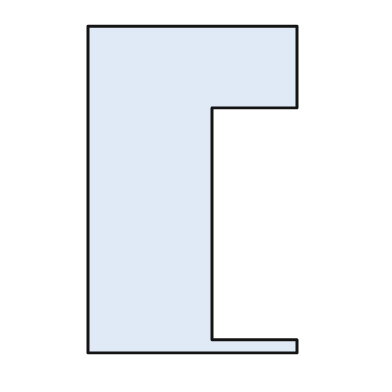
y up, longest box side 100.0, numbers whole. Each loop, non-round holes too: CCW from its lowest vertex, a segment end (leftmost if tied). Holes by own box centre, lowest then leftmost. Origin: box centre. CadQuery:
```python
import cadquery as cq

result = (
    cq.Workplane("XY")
    .moveTo(-32.0, -50.0)
    .lineTo(32.0, -50.0)
    .lineTo(32.0, -46.0)
    .lineTo(6.0, -46.0)
    .lineTo(6.0, 25.0)
    .lineTo(32.0, 25.0)
    .lineTo(32.0, 50.0)
    .lineTo(-32.0, 50.0)
    .close()
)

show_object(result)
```